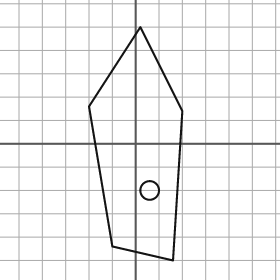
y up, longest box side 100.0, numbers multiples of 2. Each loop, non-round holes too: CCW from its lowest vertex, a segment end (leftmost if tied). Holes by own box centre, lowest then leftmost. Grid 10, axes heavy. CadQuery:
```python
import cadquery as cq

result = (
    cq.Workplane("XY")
    .moveTo(16.0, -50.0)
    .lineTo(20.0, 14.0)
    .lineTo(2.0, 50.0)
    .lineTo(-20.0, 16.0)
    .lineTo(-10.0, -44.0)
    .close()
    .moveTo(6.0, -20.0)
    .circle(4.0)
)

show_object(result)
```